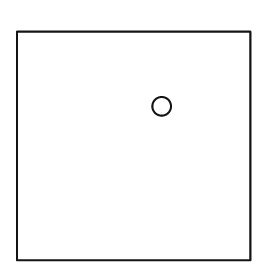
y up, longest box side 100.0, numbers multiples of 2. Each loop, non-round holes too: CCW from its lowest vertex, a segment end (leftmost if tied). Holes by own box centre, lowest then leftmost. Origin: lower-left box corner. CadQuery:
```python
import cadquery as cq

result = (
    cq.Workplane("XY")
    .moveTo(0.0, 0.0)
    .lineTo(100.0, 0.0)
    .lineTo(100.0, 98.0)
    .lineTo(0.0, 98.0)
    .close()
    .moveTo(62.0, 66.0)
    .circle(4.0)
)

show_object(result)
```